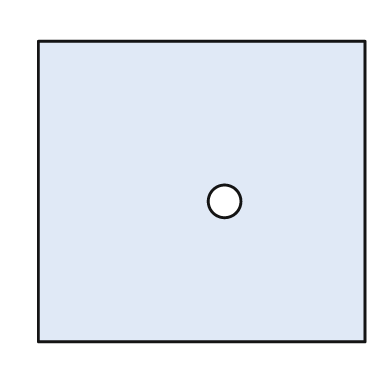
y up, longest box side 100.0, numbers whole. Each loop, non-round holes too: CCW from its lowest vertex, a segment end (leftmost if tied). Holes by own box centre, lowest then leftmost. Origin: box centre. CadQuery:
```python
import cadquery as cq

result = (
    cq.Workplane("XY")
    .moveTo(-50.0, -46.0)
    .lineTo(50.0, -46.0)
    .lineTo(50.0, 46.0)
    .lineTo(-50.0, 46.0)
    .close()
    .moveTo(7.0, -3.0)
    .circle(5.0)
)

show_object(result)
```